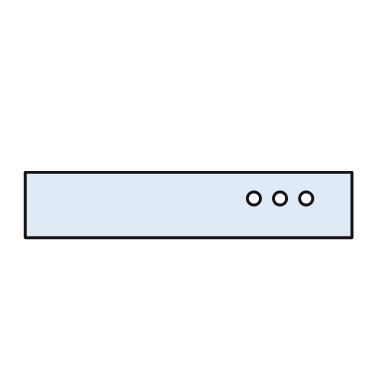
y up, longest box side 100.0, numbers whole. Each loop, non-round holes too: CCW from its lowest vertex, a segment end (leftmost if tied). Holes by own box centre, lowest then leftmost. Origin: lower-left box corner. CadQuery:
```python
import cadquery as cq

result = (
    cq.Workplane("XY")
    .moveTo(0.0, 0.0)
    .lineTo(100.0, 0.0)
    .lineTo(100.0, 20.0)
    .lineTo(0.0, 20.0)
    .close()
    .moveTo(70.0, 12.0)
    .circle(2.0)
    .moveTo(78.0, 12.0)
    .circle(2.0)
    .moveTo(86.0, 12.0)
    .circle(2.0)
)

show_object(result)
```